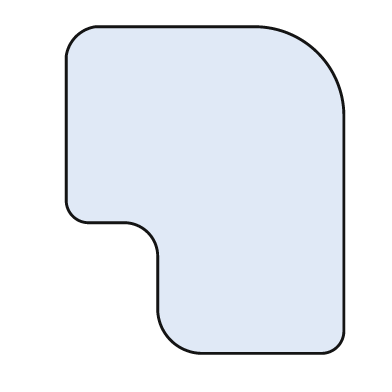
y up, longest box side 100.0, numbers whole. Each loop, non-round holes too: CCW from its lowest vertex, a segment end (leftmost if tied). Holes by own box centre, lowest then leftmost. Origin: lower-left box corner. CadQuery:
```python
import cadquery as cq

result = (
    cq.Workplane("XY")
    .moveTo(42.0, 0.0)
    .lineTo(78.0, 0.0)
    .threePointArc((83.0, 2.0), (85.0, 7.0))
    .lineTo(85.0, 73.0)
    .threePointArc((77.0, 92.0), (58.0, 100.0))
    .lineTo(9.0, 100.0)
    .threePointArc((3.0, 97.0), (0.0, 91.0))
    .lineTo(0.0, 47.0)
    .threePointArc((2.0, 42.0), (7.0, 40.0))
    .lineTo(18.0, 40.0)
    .threePointArc((25.0, 37.0), (28.0, 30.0))
    .lineTo(28.0, 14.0)
    .threePointArc((32.0, 4.0), (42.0, 0.0))
    .close()
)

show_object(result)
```